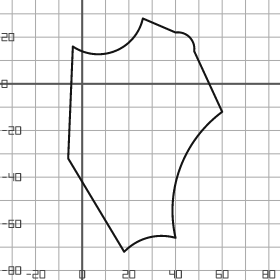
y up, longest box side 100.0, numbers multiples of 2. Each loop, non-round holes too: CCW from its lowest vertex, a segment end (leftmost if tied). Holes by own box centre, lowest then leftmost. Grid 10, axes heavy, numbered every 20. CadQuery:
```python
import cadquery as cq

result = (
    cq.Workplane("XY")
    .moveTo(18.0, -72.0)
    .threePointArc((28.0, -66.0), (40.0, -66.0))
    .threePointArc((42.0, -36.0), (60.0, -12.0))
    .lineTo(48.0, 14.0)
    .threePointArc((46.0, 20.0), (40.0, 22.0))
    .lineTo(26.0, 28.0)
    .threePointArc((14.0, 14.0), (-4.0, 16.0))
    .lineTo(-6.0, -32.0)
    .close()
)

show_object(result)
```